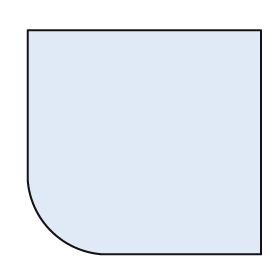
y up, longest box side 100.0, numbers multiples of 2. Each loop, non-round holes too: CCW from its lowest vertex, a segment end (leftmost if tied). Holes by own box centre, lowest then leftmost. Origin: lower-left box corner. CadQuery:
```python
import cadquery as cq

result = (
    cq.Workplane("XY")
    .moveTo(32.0, 0.0)
    .lineTo(100.0, 0.0)
    .lineTo(100.0, 96.0)
    .lineTo(0.0, 96.0)
    .lineTo(0.0, 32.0)
    .threePointArc((10.0, 10.0), (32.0, 0.0))
    .close()
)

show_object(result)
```